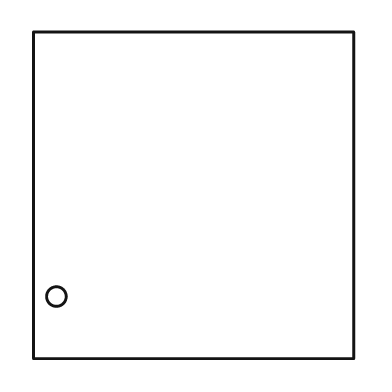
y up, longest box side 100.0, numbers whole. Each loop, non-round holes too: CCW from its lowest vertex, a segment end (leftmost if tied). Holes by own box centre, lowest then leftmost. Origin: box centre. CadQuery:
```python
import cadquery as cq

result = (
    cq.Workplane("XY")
    .moveTo(-49.0, -50.0)
    .lineTo(49.0, -50.0)
    .lineTo(49.0, 50.0)
    .lineTo(-49.0, 50.0)
    .close()
    .moveTo(-42.0, -31.0)
    .circle(3.0)
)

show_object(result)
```